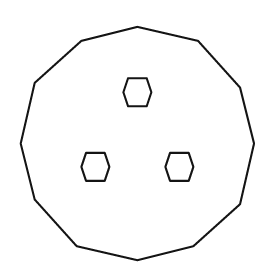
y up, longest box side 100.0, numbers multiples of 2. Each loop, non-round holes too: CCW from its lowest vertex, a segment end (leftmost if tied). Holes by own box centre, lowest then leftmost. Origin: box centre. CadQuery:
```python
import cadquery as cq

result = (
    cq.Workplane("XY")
    .moveTo(0.0, -50.0)
    .lineTo(24.0, -44.0)
    .lineTo(44.0, -26.0)
    .lineTo(50.0, 0.0)
    .lineTo(44.0, 24.0)
    .lineTo(26.0, 44.0)
    .lineTo(0.0, 50.0)
    .lineTo(-24.0, 44.0)
    .lineTo(-44.0, 26.0)
    .lineTo(-50.0, 0.0)
    .lineTo(-44.0, -24.0)
    .lineTo(-26.0, -44.0)
    .close()
    .moveTo(-22.0, -16.0)
    .lineTo(-14.0, -16.0)
    .lineTo(-12.0, -10.0)
    .lineTo(-14.0, -4.0)
    .lineTo(-22.0, -4.0)
    .lineTo(-24.0, -10.0)
    .close()
    .moveTo(14.0, -16.0)
    .lineTo(22.0, -16.0)
    .lineTo(24.0, -10.0)
    .lineTo(22.0, -4.0)
    .lineTo(14.0, -4.0)
    .lineTo(12.0, -10.0)
    .close()
    .moveTo(-4.0, 16.0)
    .lineTo(4.0, 16.0)
    .lineTo(6.0, 22.0)
    .lineTo(4.0, 28.0)
    .lineTo(-4.0, 28.0)
    .lineTo(-6.0, 22.0)
    .close()
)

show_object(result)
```